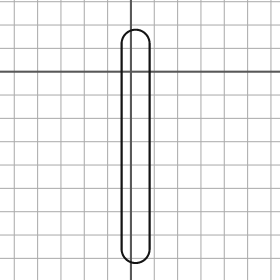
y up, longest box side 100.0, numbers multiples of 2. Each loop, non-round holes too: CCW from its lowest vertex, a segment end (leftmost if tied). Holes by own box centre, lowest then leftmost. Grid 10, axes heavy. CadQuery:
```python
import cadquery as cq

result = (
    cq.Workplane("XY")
    .moveTo(-4.0, -76.0)
    .threePointArc((2.0, -82.0), (8.0, -76.0))
    .lineTo(8.0, 12.0)
    .threePointArc((2.0, 18.0), (-4.0, 12.0))
    .close()
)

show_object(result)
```